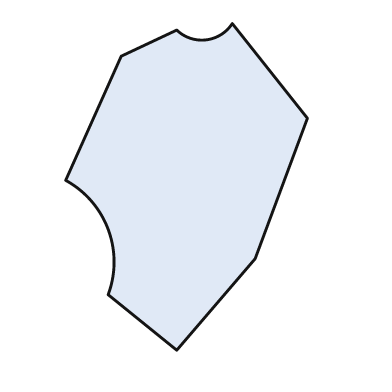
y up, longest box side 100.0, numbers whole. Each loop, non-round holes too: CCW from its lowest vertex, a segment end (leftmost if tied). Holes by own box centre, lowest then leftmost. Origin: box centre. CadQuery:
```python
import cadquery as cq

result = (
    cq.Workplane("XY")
    .moveTo(-3.0, -50.0)
    .lineTo(21.0, -22.0)
    .lineTo(37.0, 21.0)
    .lineTo(14.0, 50.0)
    .threePointArc((6.0, 45.0), (-3.0, 48.0))
    .lineTo(-20.0, 40.0)
    .lineTo(-37.0, 2.0)
    .threePointArc((-24.0, -13.0), (-24.0, -33.0))
    .close()
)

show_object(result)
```